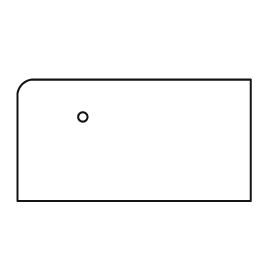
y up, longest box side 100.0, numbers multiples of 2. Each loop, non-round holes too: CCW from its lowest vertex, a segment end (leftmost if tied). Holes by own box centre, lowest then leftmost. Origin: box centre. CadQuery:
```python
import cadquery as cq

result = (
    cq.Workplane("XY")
    .moveTo(-50.0, -26.0)
    .lineTo(50.0, -26.0)
    .lineTo(50.0, 26.0)
    .lineTo(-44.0, 26.0)
    .threePointArc((-48.0, 24.0), (-50.0, 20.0))
    .close()
    .moveTo(-22.0, 10.0)
    .circle(2.0)
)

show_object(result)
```